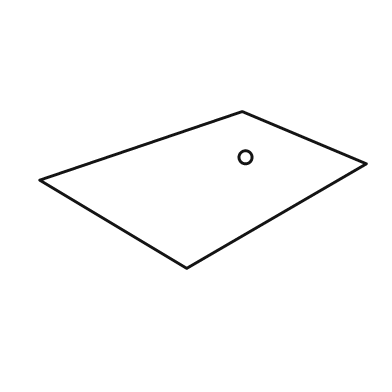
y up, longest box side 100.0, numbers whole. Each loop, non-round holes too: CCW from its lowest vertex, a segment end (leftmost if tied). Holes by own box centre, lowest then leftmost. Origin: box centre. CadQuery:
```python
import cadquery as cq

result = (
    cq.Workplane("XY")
    .moveTo(-5.0, -24.0)
    .lineTo(50.0, 8.0)
    .lineTo(12.0, 24.0)
    .lineTo(-50.0, 3.0)
    .close()
    .moveTo(13.0, 10.0)
    .circle(2.0)
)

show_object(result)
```